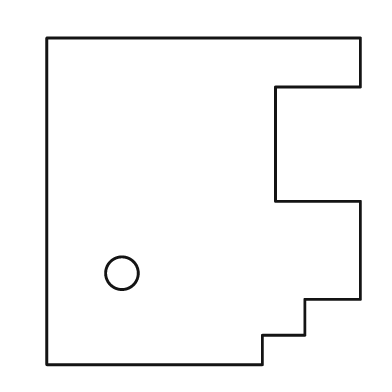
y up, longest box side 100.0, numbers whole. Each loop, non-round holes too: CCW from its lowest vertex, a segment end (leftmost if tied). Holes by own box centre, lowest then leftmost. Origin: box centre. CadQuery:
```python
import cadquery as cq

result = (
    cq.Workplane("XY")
    .moveTo(-48.0, -50.0)
    .lineTo(18.0, -50.0)
    .lineTo(18.0, -41.0)
    .lineTo(31.0, -41.0)
    .lineTo(31.0, -30.0)
    .lineTo(48.0, -30.0)
    .lineTo(48.0, 0.0)
    .lineTo(22.0, 0.0)
    .lineTo(22.0, 35.0)
    .lineTo(48.0, 35.0)
    .lineTo(48.0, 50.0)
    .lineTo(-48.0, 50.0)
    .close()
    .moveTo(-25.0, -22.0)
    .circle(5.0)
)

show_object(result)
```